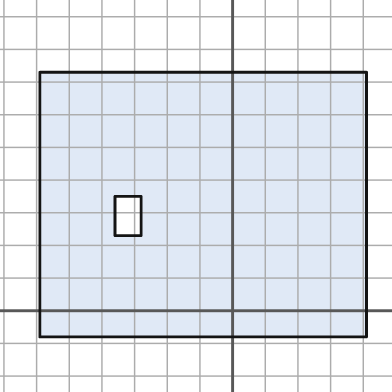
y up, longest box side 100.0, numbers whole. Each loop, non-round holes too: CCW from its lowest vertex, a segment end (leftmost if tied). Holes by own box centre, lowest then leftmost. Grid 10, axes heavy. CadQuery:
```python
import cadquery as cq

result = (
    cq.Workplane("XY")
    .moveTo(-59.0, -8.0)
    .lineTo(41.0, -8.0)
    .lineTo(41.0, 73.0)
    .lineTo(-59.0, 73.0)
    .close()
    .moveTo(-36.0, 23.0)
    .lineTo(-28.0, 23.0)
    .lineTo(-28.0, 35.0)
    .lineTo(-36.0, 35.0)
    .close()
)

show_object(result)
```